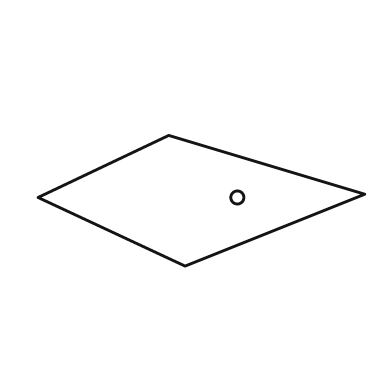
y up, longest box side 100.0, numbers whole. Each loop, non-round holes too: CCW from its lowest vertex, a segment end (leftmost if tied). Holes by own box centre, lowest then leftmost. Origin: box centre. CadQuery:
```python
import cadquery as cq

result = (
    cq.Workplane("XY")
    .moveTo(-5.0, -20.0)
    .lineTo(50.0, 2.0)
    .lineTo(-10.0, 20.0)
    .lineTo(-50.0, 1.0)
    .close()
    .moveTo(11.0, 1.0)
    .circle(2.0)
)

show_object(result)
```